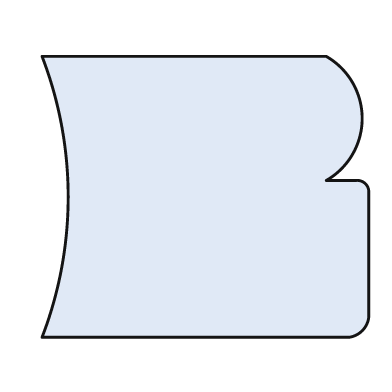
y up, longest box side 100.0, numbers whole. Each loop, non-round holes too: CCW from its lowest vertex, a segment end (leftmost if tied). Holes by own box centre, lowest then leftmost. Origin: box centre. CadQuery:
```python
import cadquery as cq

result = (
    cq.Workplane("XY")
    .moveTo(-50.0, -43.0)
    .lineTo(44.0, -43.0)
    .threePointArc((48.0, -41.0), (50.0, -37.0))
    .lineTo(50.0, 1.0)
    .threePointArc((49.0, 4.0), (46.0, 5.0))
    .lineTo(37.0, 5.0)
    .threePointArc((48.0, 24.0), (37.0, 43.0))
    .lineTo(-50.0, 43.0)
    .threePointArc((-42.0, 0.0), (-50.0, -43.0))
    .close()
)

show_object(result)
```